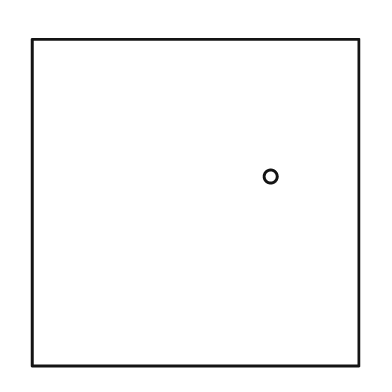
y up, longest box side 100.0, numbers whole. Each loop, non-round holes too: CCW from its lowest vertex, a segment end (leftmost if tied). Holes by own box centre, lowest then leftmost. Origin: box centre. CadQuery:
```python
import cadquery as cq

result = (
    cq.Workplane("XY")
    .moveTo(-50.0, -50.0)
    .lineTo(50.0, -50.0)
    .lineTo(50.0, 50.0)
    .lineTo(-50.0, 50.0)
    .close()
    .moveTo(23.0, 8.0)
    .circle(2.0)
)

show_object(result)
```